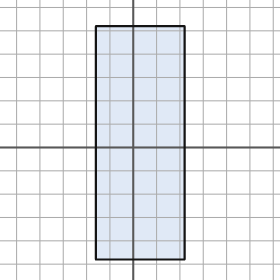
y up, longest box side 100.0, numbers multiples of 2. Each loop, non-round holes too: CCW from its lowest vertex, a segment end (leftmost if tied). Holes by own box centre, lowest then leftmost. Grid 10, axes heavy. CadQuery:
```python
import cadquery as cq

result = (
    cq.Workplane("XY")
    .moveTo(-16.0, -48.0)
    .lineTo(22.0, -48.0)
    .lineTo(22.0, 52.0)
    .lineTo(-16.0, 52.0)
    .close()
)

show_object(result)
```